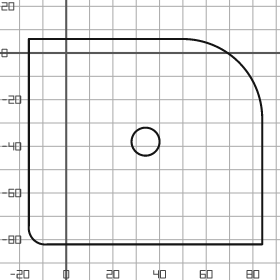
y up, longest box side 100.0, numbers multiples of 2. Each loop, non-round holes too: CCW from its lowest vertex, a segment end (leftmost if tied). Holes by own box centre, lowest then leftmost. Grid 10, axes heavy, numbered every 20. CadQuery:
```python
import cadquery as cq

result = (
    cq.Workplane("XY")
    .moveTo(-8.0, -82.0)
    .lineTo(84.0, -82.0)
    .lineTo(84.0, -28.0)
    .threePointArc((74.0, -4.0), (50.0, 6.0))
    .lineTo(-16.0, 6.0)
    .lineTo(-16.0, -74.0)
    .threePointArc((-14.0, -80.0), (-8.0, -82.0))
    .close()
    .moveTo(34.0, -38.0)
    .circle(6.0)
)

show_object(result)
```